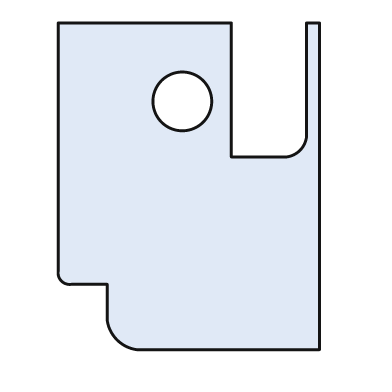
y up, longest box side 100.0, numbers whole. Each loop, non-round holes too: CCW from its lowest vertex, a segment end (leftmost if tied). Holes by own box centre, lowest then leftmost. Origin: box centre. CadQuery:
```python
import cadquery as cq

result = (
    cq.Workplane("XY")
    .moveTo(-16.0, -50.0)
    .lineTo(40.0, -50.0)
    .lineTo(40.0, 50.0)
    .lineTo(36.0, 50.0)
    .lineTo(36.0, 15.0)
    .threePointArc((34.0, 11.0), (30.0, 9.0))
    .lineTo(13.0, 9.0)
    .lineTo(13.0, 50.0)
    .lineTo(-40.0, 50.0)
    .lineTo(-40.0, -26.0)
    .threePointArc((-39.0, -29.0), (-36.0, -30.0))
    .lineTo(-25.0, -30.0)
    .lineTo(-25.0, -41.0)
    .threePointArc((-22.0, -47.0), (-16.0, -50.0))
    .close()
    .moveTo(-2.0, 26.0)
    .circle(9.0)
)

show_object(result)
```